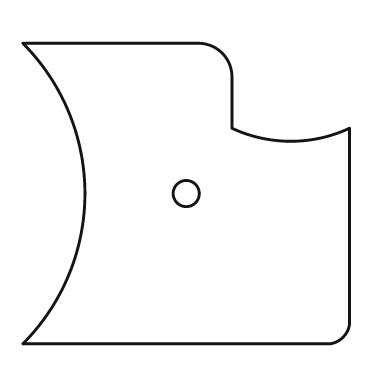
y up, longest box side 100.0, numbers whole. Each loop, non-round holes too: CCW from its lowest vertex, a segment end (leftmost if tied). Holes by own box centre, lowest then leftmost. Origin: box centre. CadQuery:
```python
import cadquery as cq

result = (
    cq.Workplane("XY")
    .moveTo(-50.0, -46.0)
    .lineTo(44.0, -46.0)
    .threePointArc((48.0, -44.0), (50.0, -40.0))
    .lineTo(50.0, 20.0)
    .threePointArc((32.0, 16.0), (14.0, 20.0))
    .lineTo(14.0, 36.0)
    .threePointArc((11.0, 43.0), (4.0, 46.0))
    .lineTo(-50.0, 46.0)
    .threePointArc((-31.0, 0.0), (-50.0, -46.0))
    .close()
    .moveTo(0.0, 0.0)
    .circle(4.0)
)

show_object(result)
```